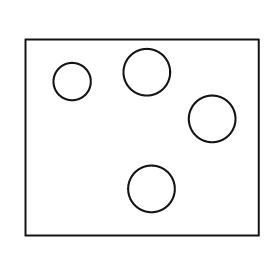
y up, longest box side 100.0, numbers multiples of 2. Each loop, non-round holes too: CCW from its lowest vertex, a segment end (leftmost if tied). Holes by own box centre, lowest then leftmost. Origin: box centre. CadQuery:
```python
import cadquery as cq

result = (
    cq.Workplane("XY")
    .moveTo(-50.0, -42.0)
    .lineTo(50.0, -42.0)
    .lineTo(50.0, 42.0)
    .lineTo(-50.0, 42.0)
    .close()
    .moveTo(4.0, -22.0)
    .circle(10.0)
    .moveTo(30.0, 8.0)
    .circle(10.0)
    .moveTo(-30.0, 24.0)
    .circle(8.0)
    .moveTo(2.0, 28.0)
    .circle(10.0)
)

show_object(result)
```